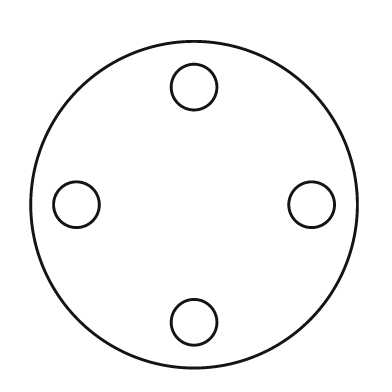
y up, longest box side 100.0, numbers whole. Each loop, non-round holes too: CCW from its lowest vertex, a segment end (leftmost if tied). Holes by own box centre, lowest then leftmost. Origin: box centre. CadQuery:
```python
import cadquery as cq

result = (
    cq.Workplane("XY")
    .moveTo(0.0, 0.0)
    .circle(50.0)
    .moveTo(0.0, -36.0)
    .circle(7.0)
    .moveTo(-36.0, 0.0)
    .circle(7.0)
    .moveTo(36.0, 0.0)
    .circle(7.0)
    .moveTo(0.0, 36.0)
    .circle(7.0)
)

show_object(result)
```